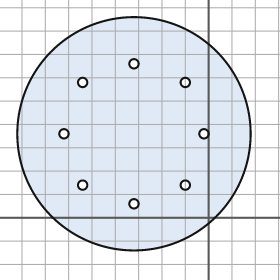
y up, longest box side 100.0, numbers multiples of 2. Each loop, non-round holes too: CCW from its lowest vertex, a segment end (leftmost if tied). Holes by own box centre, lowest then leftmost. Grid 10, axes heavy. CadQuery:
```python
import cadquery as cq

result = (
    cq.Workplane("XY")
    .moveTo(-32.0, 36.0)
    .circle(50.0)
    .moveTo(-32.0, 6.0)
    .circle(2.0)
    .moveTo(-54.0, 14.0)
    .circle(2.0)
    .moveTo(-10.0, 14.0)
    .circle(2.0)
    .moveTo(-62.0, 36.0)
    .circle(2.0)
    .moveTo(-2.0, 36.0)
    .circle(2.0)
    .moveTo(-54.0, 58.0)
    .circle(2.0)
    .moveTo(-10.0, 58.0)
    .circle(2.0)
    .moveTo(-32.0, 66.0)
    .circle(2.0)
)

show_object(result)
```